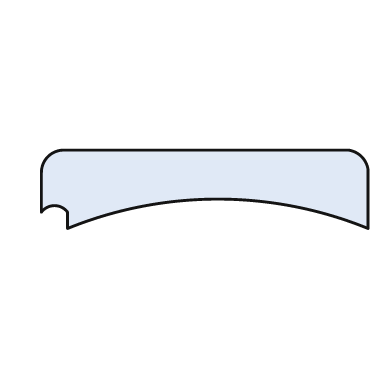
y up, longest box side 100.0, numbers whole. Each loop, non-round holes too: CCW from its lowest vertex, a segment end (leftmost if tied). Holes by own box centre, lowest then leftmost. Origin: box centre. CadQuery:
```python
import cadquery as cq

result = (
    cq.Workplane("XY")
    .moveTo(-42.0, -12.0)
    .threePointArc((4.0, -3.0), (50.0, -12.0))
    .lineTo(50.0, 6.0)
    .threePointArc((48.0, 10.0), (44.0, 12.0))
    .lineTo(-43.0, 12.0)
    .threePointArc((-48.0, 10.0), (-50.0, 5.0))
    .lineTo(-50.0, -7.0)
    .threePointArc((-46.0, -5.0), (-42.0, -7.0))
    .close()
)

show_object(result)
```